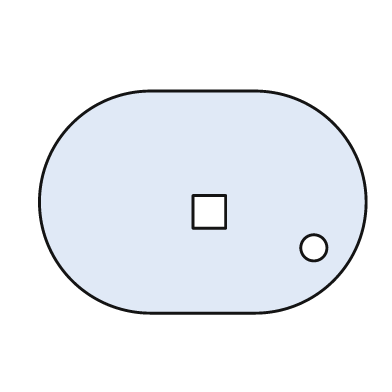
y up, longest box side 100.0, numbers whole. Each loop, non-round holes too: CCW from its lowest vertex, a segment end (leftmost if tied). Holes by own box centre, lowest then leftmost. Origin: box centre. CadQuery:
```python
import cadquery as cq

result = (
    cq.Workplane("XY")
    .moveTo(-16.0, -34.0)
    .lineTo(16.0, -34.0)
    .threePointArc((50.0, 0.0), (16.0, 34.0))
    .lineTo(-16.0, 34.0)
    .threePointArc((-50.0, 0.0), (-16.0, -34.0))
    .close()
    .moveTo(34.0, -14.0)
    .circle(4.0)
    .moveTo(-3.0, -8.0)
    .lineTo(7.0, -8.0)
    .lineTo(7.0, 2.0)
    .lineTo(-3.0, 2.0)
    .close()
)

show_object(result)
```